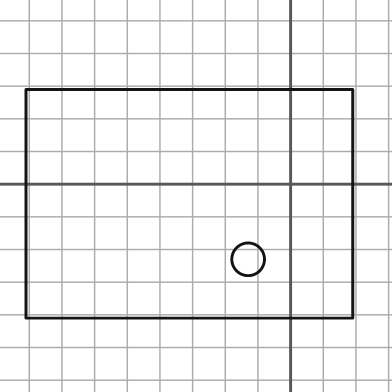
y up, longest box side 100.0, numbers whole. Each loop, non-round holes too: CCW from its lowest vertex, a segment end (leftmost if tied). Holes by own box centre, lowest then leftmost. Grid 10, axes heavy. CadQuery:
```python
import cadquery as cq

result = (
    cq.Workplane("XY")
    .moveTo(-81.0, -41.0)
    .lineTo(19.0, -41.0)
    .lineTo(19.0, 29.0)
    .lineTo(-81.0, 29.0)
    .close()
    .moveTo(-13.0, -23.0)
    .circle(5.0)
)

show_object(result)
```